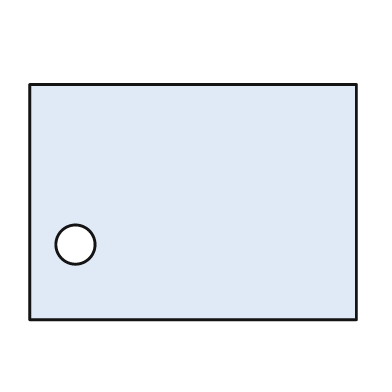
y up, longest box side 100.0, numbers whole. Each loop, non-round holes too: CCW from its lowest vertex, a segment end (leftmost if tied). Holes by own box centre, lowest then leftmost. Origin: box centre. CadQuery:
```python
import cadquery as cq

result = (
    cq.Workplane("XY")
    .moveTo(-50.0, -36.0)
    .lineTo(50.0, -36.0)
    .lineTo(50.0, 36.0)
    .lineTo(-50.0, 36.0)
    .close()
    .moveTo(-36.0, -13.0)
    .circle(6.0)
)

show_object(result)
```